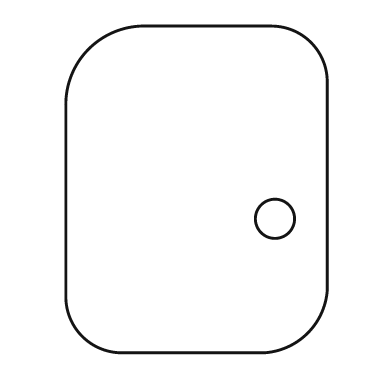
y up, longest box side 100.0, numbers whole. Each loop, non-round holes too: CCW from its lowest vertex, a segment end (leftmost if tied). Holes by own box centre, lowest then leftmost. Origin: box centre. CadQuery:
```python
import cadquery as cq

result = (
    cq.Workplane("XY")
    .moveTo(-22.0, -50.0)
    .lineTo(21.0, -50.0)
    .threePointArc((34.0, -44.0), (40.0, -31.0))
    .lineTo(40.0, 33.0)
    .threePointArc((35.0, 45.0), (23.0, 50.0))
    .lineTo(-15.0, 50.0)
    .threePointArc((-33.0, 43.0), (-40.0, 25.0))
    .lineTo(-40.0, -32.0)
    .threePointArc((-35.0, -45.0), (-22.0, -50.0))
    .close()
    .moveTo(24.0, -9.0)
    .circle(6.0)
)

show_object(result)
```